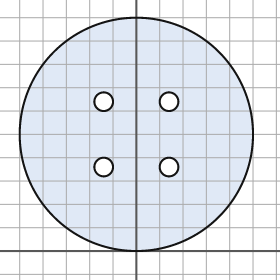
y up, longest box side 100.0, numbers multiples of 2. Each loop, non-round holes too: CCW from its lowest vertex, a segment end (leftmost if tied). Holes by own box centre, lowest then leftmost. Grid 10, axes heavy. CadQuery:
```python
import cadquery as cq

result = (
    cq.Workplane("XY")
    .moveTo(0.0, 50.0)
    .circle(50.0)
    .moveTo(-14.0, 36.0)
    .circle(4.0)
    .moveTo(14.0, 36.0)
    .circle(4.0)
    .moveTo(-14.0, 64.0)
    .circle(4.0)
    .moveTo(14.0, 64.0)
    .circle(4.0)
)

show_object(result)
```